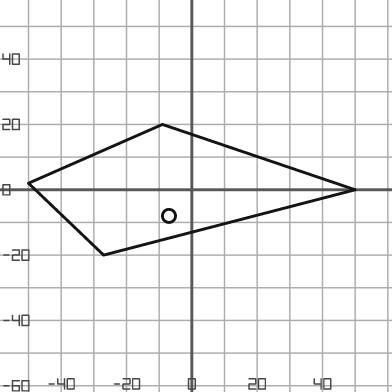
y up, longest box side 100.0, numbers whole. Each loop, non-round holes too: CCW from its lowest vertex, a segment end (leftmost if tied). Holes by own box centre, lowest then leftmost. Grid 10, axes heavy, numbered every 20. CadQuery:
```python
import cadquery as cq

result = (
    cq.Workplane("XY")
    .moveTo(-27.0, -20.0)
    .lineTo(50.0, 0.0)
    .lineTo(-9.0, 20.0)
    .lineTo(-50.0, 2.0)
    .close()
    .moveTo(-7.0, -8.0)
    .circle(2.0)
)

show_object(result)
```